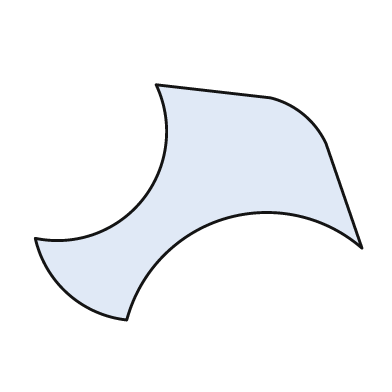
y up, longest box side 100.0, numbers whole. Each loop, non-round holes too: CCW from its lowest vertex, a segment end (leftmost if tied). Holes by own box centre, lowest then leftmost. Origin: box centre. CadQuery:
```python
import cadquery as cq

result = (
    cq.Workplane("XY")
    .moveTo(-22.0, -36.0)
    .threePointArc((8.0, -5.0), (50.0, -14.0))
    .lineTo(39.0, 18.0)
    .threePointArc((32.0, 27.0), (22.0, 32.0))
    .lineTo(-13.0, 36.0)
    .threePointArc((-17.0, 1.0), (-50.0, -11.0))
    .threePointArc((-40.0, -28.0), (-22.0, -36.0))
    .close()
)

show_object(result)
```